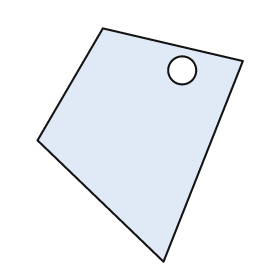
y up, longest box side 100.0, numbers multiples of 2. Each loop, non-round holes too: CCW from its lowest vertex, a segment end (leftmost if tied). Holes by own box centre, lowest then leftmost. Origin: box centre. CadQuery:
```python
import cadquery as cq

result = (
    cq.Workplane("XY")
    .moveTo(10.0, -50.0)
    .lineTo(44.0, 36.0)
    .lineTo(-16.0, 50.0)
    .lineTo(-44.0, 2.0)
    .close()
    .moveTo(18.0, 32.0)
    .circle(6.0)
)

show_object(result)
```